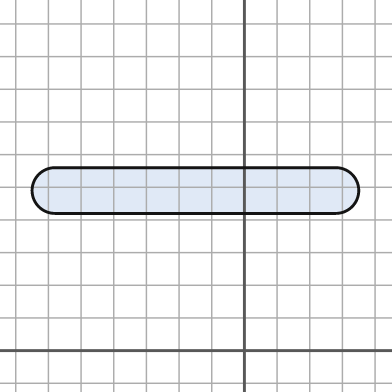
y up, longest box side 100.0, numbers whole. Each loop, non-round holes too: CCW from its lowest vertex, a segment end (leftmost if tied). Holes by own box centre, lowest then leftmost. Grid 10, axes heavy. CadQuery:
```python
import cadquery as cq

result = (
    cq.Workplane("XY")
    .moveTo(-58.0, 42.0)
    .lineTo(28.0, 42.0)
    .threePointArc((35.0, 49.0), (28.0, 56.0))
    .lineTo(-58.0, 56.0)
    .threePointArc((-65.0, 49.0), (-58.0, 42.0))
    .close()
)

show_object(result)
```